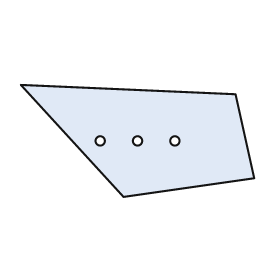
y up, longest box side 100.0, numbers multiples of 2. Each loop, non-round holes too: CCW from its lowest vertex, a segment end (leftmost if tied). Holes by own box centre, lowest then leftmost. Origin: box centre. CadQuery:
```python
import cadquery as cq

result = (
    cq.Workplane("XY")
    .moveTo(-6.0, -24.0)
    .lineTo(50.0, -16.0)
    .lineTo(42.0, 20.0)
    .lineTo(-50.0, 24.0)
    .close()
    .moveTo(-16.0, 0.0)
    .circle(2.0)
    .moveTo(0.0, 0.0)
    .circle(2.0)
    .moveTo(16.0, 0.0)
    .circle(2.0)
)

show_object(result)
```